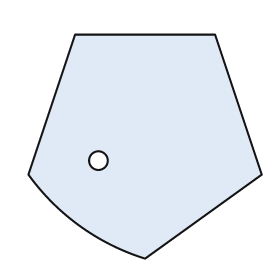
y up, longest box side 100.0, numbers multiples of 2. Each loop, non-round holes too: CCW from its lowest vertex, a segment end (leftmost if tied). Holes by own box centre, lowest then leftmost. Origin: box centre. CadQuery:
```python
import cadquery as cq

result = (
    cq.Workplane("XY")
    .moveTo(0.0, -48.0)
    .lineTo(50.0, -12.0)
    .lineTo(30.0, 48.0)
    .lineTo(-30.0, 48.0)
    .lineTo(-50.0, -12.0)
    .threePointArc((-28.0, -34.0), (0.0, -48.0))
    .close()
    .moveTo(-20.0, -6.0)
    .circle(4.0)
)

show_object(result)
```